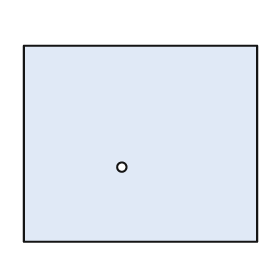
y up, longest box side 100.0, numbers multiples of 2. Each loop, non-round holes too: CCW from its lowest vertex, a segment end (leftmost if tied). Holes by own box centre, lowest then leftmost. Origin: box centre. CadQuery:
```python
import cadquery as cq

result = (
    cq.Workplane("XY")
    .moveTo(-50.0, -42.0)
    .lineTo(50.0, -42.0)
    .lineTo(50.0, 42.0)
    .lineTo(-50.0, 42.0)
    .close()
    .moveTo(-8.0, -10.0)
    .circle(2.0)
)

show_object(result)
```